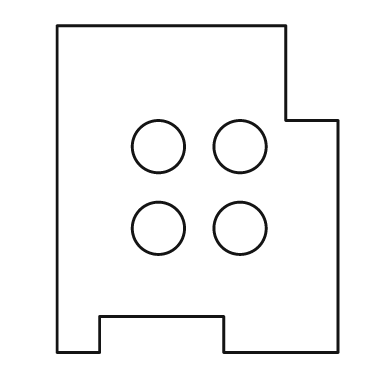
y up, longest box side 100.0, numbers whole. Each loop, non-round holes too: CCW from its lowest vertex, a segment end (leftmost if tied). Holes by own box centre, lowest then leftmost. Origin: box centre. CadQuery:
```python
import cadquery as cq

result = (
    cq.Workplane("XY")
    .moveTo(-43.0, -50.0)
    .lineTo(-30.0, -50.0)
    .lineTo(-30.0, -39.0)
    .lineTo(8.0, -39.0)
    .lineTo(8.0, -50.0)
    .lineTo(43.0, -50.0)
    .lineTo(43.0, 21.0)
    .lineTo(27.0, 21.0)
    .lineTo(27.0, 50.0)
    .lineTo(-43.0, 50.0)
    .close()
    .moveTo(-12.0, -12.0)
    .circle(8.0)
    .moveTo(13.0, -12.0)
    .circle(8.0)
    .moveTo(-12.0, 13.0)
    .circle(8.0)
    .moveTo(13.0, 13.0)
    .circle(8.0)
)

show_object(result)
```